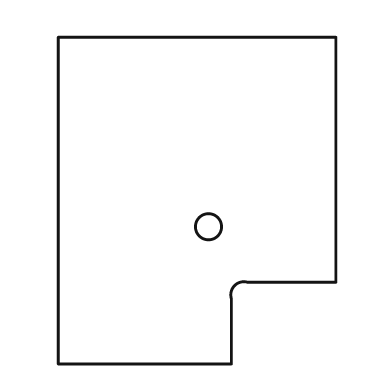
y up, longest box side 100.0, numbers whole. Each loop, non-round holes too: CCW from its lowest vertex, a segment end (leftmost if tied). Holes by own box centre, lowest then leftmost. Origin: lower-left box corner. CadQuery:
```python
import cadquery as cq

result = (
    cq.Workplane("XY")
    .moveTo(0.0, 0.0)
    .lineTo(53.0, 0.0)
    .lineTo(53.0, 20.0)
    .threePointArc((54.0, 24.0), (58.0, 25.0))
    .lineTo(85.0, 25.0)
    .lineTo(85.0, 100.0)
    .lineTo(0.0, 100.0)
    .close()
    .moveTo(46.0, 42.0)
    .circle(4.0)
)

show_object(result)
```